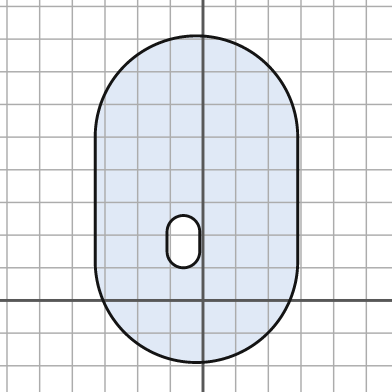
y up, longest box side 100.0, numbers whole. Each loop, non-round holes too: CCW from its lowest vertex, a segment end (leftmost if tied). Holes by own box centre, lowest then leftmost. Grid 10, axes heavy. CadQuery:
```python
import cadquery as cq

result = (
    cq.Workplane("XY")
    .moveTo(-33.0, 12.0)
    .threePointArc((-2.0, -19.0), (29.0, 12.0))
    .lineTo(29.0, 50.0)
    .threePointArc((-2.0, 81.0), (-33.0, 50.0))
    .close()
    .moveTo(-11.0, 15.0)
    .threePointArc((-6.0, 10.0), (-1.0, 15.0))
    .lineTo(-1.0, 21.0)
    .threePointArc((-6.0, 26.0), (-11.0, 21.0))
    .close()
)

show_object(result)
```